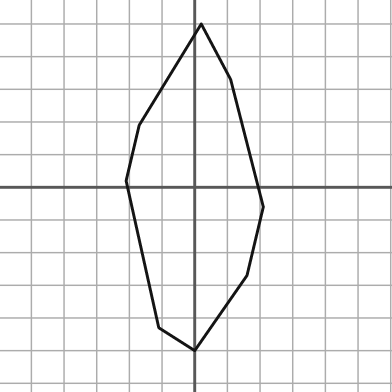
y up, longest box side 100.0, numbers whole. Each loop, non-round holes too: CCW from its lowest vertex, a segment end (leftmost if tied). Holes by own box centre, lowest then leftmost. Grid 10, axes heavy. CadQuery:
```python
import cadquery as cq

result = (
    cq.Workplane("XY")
    .moveTo(0.0, -50.0)
    .lineTo(16.0, -27.0)
    .lineTo(21.0, -6.0)
    .lineTo(11.0, 33.0)
    .lineTo(2.0, 50.0)
    .lineTo(-17.0, 19.0)
    .lineTo(-21.0, 2.0)
    .lineTo(-11.0, -43.0)
    .close()
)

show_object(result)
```